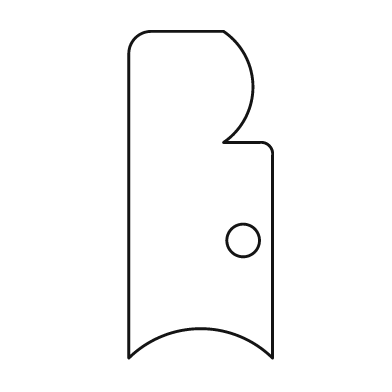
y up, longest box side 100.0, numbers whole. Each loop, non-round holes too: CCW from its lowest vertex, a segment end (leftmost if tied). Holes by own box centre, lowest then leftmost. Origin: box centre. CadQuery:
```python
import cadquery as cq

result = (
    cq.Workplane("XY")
    .moveTo(-22.0, -50.0)
    .threePointArc((0.0, -41.0), (22.0, -50.0))
    .lineTo(22.0, 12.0)
    .threePointArc((21.0, 15.0), (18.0, 16.0))
    .lineTo(7.0, 16.0)
    .threePointArc((16.0, 33.0), (7.0, 50.0))
    .lineTo(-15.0, 50.0)
    .threePointArc((-20.0, 48.0), (-22.0, 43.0))
    .close()
    .moveTo(13.0, -14.0)
    .circle(5.0)
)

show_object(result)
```